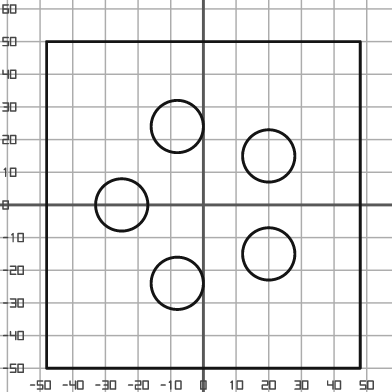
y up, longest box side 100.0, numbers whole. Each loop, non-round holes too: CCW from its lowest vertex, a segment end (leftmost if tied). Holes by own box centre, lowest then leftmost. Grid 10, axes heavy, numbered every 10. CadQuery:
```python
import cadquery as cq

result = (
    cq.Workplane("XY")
    .moveTo(-48.0, -50.0)
    .lineTo(48.0, -50.0)
    .lineTo(48.0, 50.0)
    .lineTo(-48.0, 50.0)
    .close()
    .moveTo(-8.0, -24.0)
    .circle(8.0)
    .moveTo(20.0, -15.0)
    .circle(8.0)
    .moveTo(-25.0, 0.0)
    .circle(8.0)
    .moveTo(20.0, 15.0)
    .circle(8.0)
    .moveTo(-8.0, 24.0)
    .circle(8.0)
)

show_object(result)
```